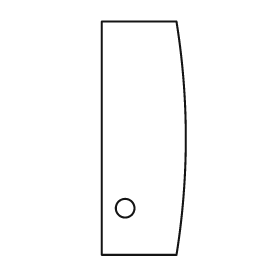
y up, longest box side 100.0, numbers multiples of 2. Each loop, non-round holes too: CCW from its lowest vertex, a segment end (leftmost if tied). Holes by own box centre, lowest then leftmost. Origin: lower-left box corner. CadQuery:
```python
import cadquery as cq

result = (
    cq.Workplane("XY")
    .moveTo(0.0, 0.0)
    .lineTo(32.0, 0.0)
    .threePointArc((36.0, 50.0), (32.0, 100.0))
    .lineTo(0.0, 100.0)
    .close()
    .moveTo(10.0, 20.0)
    .circle(4.0)
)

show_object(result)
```